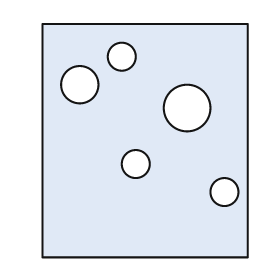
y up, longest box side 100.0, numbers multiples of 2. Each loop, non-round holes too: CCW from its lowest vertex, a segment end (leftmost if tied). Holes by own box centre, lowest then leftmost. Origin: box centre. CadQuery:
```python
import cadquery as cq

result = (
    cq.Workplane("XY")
    .moveTo(-44.0, -50.0)
    .lineTo(44.0, -50.0)
    .lineTo(44.0, 50.0)
    .lineTo(-44.0, 50.0)
    .close()
    .moveTo(34.0, -22.0)
    .circle(6.0)
    .moveTo(-4.0, -10.0)
    .circle(6.0)
    .moveTo(18.0, 14.0)
    .circle(10.0)
    .moveTo(-28.0, 24.0)
    .circle(8.0)
    .moveTo(-10.0, 36.0)
    .circle(6.0)
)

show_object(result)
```